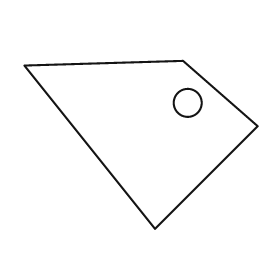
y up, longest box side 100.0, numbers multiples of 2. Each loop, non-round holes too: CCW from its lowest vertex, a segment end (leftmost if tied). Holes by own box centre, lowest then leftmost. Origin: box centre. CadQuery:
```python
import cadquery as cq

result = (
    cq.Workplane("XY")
    .moveTo(6.0, -36.0)
    .lineTo(50.0, 8.0)
    .lineTo(18.0, 36.0)
    .lineTo(-50.0, 34.0)
    .close()
    .moveTo(20.0, 18.0)
    .circle(6.0)
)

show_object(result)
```